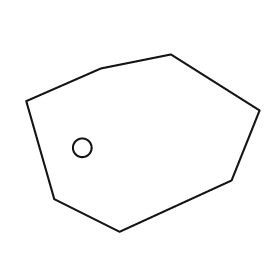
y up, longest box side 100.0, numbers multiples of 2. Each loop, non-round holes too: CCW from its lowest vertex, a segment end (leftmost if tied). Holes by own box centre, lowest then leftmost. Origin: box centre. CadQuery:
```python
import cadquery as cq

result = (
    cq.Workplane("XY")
    .moveTo(-10.0, -38.0)
    .lineTo(38.0, -16.0)
    .lineTo(50.0, 14.0)
    .lineTo(12.0, 38.0)
    .lineTo(-18.0, 32.0)
    .lineTo(-50.0, 18.0)
    .lineTo(-38.0, -24.0)
    .close()
    .moveTo(-26.0, -2.0)
    .circle(4.0)
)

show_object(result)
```